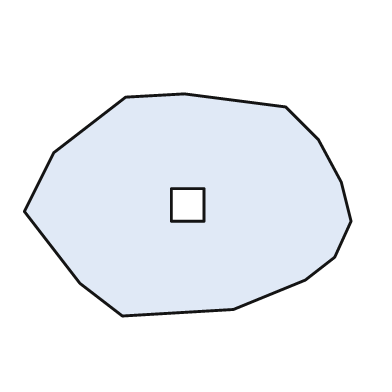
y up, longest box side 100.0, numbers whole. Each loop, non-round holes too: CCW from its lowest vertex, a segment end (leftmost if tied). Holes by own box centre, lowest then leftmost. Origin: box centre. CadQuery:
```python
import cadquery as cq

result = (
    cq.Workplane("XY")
    .moveTo(-20.0, -34.0)
    .lineTo(14.0, -32.0)
    .lineTo(36.0, -23.0)
    .lineTo(45.0, -16.0)
    .lineTo(50.0, -5.0)
    .lineTo(47.0, 7.0)
    .lineTo(40.0, 20.0)
    .lineTo(30.0, 30.0)
    .lineTo(-1.0, 34.0)
    .lineTo(-19.0, 33.0)
    .lineTo(-41.0, 16.0)
    .lineTo(-50.0, -2.0)
    .lineTo(-33.0, -24.0)
    .close()
    .moveTo(-5.0, -5.0)
    .lineTo(5.0, -5.0)
    .lineTo(5.0, 5.0)
    .lineTo(-5.0, 5.0)
    .close()
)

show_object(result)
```